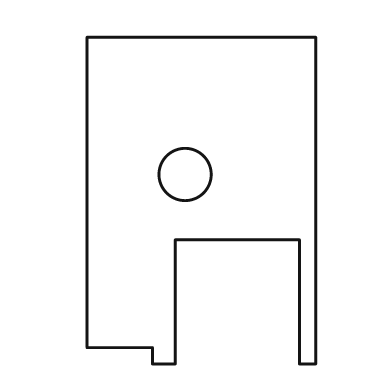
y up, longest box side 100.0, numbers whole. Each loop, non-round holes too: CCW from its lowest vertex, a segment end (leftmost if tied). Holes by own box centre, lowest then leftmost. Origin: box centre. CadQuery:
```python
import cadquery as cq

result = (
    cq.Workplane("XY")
    .moveTo(-15.0, -50.0)
    .lineTo(-8.0, -50.0)
    .lineTo(-8.0, -12.0)
    .lineTo(30.0, -12.0)
    .lineTo(30.0, -50.0)
    .lineTo(35.0, -50.0)
    .lineTo(35.0, 50.0)
    .lineTo(-35.0, 50.0)
    .lineTo(-35.0, -45.0)
    .lineTo(-15.0, -45.0)
    .close()
    .moveTo(-5.0, 8.0)
    .circle(8.0)
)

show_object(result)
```